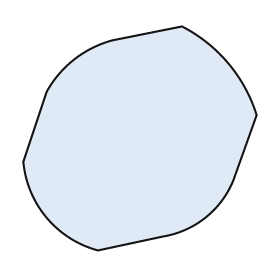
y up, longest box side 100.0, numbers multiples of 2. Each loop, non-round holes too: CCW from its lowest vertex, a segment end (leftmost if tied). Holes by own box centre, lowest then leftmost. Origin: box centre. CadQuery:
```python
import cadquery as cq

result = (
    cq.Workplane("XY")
    .moveTo(-18.0, -48.0)
    .lineTo(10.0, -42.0)
    .threePointArc((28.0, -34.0), (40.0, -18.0))
    .lineTo(50.0, 10.0)
    .threePointArc((38.0, 32.0), (18.0, 48.0))
    .lineTo(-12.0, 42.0)
    .threePointArc((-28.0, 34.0), (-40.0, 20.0))
    .lineTo(-50.0, -10.0)
    .threePointArc((-40.0, -34.0), (-18.0, -48.0))
    .close()
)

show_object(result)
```